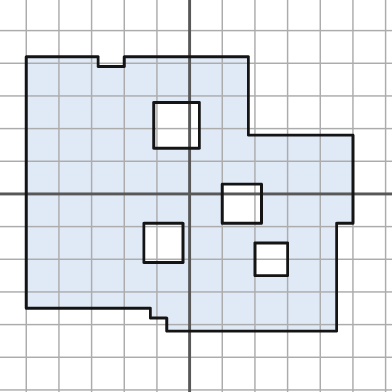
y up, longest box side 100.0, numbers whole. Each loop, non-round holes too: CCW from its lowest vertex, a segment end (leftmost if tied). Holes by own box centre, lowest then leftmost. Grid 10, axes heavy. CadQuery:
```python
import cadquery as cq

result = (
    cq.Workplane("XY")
    .moveTo(-7.0, -42.0)
    .lineTo(45.0, -42.0)
    .lineTo(45.0, -9.0)
    .lineTo(50.0, -9.0)
    .lineTo(50.0, 18.0)
    .lineTo(18.0, 18.0)
    .lineTo(18.0, 42.0)
    .lineTo(-20.0, 42.0)
    .lineTo(-20.0, 39.0)
    .lineTo(-28.0, 39.0)
    .lineTo(-28.0, 42.0)
    .lineTo(-50.0, 42.0)
    .lineTo(-50.0, -35.0)
    .lineTo(-12.0, -35.0)
    .lineTo(-12.0, -38.0)
    .lineTo(-7.0, -38.0)
    .close()
    .moveTo(20.0, -25.0)
    .lineTo(30.0, -25.0)
    .lineTo(30.0, -15.0)
    .lineTo(20.0, -15.0)
    .close()
    .moveTo(-14.0, -21.0)
    .lineTo(-2.0, -21.0)
    .lineTo(-2.0, -9.0)
    .lineTo(-14.0, -9.0)
    .close()
    .moveTo(10.0, -9.0)
    .lineTo(22.0, -9.0)
    .lineTo(22.0, 3.0)
    .lineTo(10.0, 3.0)
    .close()
    .moveTo(-11.0, 14.0)
    .lineTo(3.0, 14.0)
    .lineTo(3.0, 28.0)
    .lineTo(-11.0, 28.0)
    .close()
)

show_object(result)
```